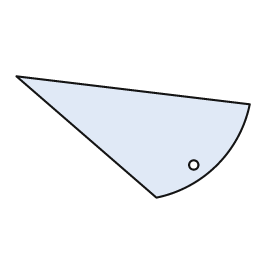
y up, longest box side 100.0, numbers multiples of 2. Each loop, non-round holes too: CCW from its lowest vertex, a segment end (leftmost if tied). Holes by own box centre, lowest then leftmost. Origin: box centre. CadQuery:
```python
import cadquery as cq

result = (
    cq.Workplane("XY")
    .moveTo(10.0, -26.0)
    .threePointArc((36.0, -12.0), (50.0, 14.0))
    .lineTo(-50.0, 26.0)
    .close()
    .moveTo(26.0, -12.0)
    .circle(2.0)
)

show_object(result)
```